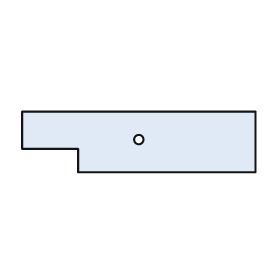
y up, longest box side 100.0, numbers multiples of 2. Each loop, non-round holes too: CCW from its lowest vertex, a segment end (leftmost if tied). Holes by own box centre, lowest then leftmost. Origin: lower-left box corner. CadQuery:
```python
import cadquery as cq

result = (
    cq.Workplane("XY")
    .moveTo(24.0, 0.0)
    .lineTo(100.0, 0.0)
    .lineTo(100.0, 26.0)
    .lineTo(0.0, 26.0)
    .lineTo(0.0, 10.0)
    .lineTo(24.0, 10.0)
    .close()
    .moveTo(50.0, 14.0)
    .circle(2.0)
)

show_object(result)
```